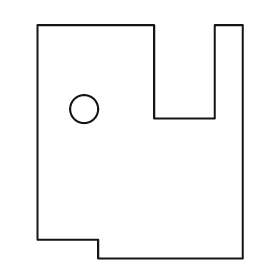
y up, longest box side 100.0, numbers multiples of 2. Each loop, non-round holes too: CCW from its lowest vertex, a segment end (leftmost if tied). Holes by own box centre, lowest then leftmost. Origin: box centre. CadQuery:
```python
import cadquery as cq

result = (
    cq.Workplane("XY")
    .moveTo(-18.0, -50.0)
    .lineTo(44.0, -50.0)
    .lineTo(44.0, 50.0)
    .lineTo(32.0, 50.0)
    .lineTo(32.0, 10.0)
    .lineTo(6.0, 10.0)
    .lineTo(6.0, 50.0)
    .lineTo(-44.0, 50.0)
    .lineTo(-44.0, -42.0)
    .lineTo(-18.0, -42.0)
    .close()
    .moveTo(-24.0, 14.0)
    .circle(6.0)
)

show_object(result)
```